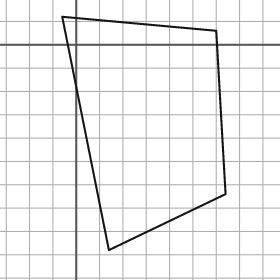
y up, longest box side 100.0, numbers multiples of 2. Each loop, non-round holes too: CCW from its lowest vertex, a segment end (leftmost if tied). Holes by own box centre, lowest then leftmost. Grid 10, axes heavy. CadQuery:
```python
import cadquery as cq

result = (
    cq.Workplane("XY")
    .moveTo(14.0, -88.0)
    .lineTo(64.0, -64.0)
    .lineTo(60.0, 6.0)
    .lineTo(-6.0, 12.0)
    .close()
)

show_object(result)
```